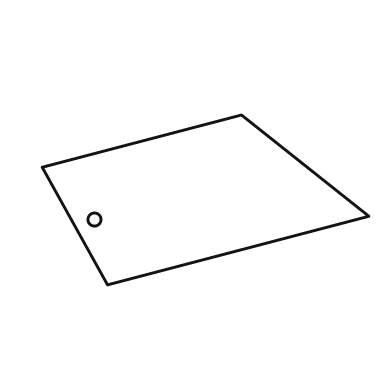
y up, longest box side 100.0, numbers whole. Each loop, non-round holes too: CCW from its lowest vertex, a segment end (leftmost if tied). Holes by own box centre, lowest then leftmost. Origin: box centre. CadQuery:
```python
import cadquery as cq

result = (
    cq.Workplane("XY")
    .moveTo(-30.0, -26.0)
    .lineTo(50.0, -5.0)
    .lineTo(11.0, 26.0)
    .lineTo(-50.0, 10.0)
    .close()
    .moveTo(-34.0, -6.0)
    .circle(2.0)
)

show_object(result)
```